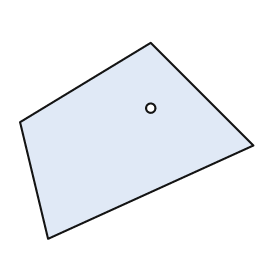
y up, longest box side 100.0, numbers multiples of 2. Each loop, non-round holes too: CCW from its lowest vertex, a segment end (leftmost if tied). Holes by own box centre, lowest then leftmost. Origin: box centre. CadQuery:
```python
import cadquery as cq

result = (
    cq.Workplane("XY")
    .moveTo(-38.0, -42.0)
    .lineTo(50.0, -2.0)
    .lineTo(6.0, 42.0)
    .lineTo(-50.0, 8.0)
    .close()
    .moveTo(6.0, 14.0)
    .circle(2.0)
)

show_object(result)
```